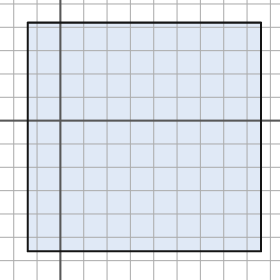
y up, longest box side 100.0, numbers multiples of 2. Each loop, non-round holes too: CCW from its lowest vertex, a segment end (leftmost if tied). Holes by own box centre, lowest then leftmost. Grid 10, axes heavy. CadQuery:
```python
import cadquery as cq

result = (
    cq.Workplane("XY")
    .moveTo(-14.0, -56.0)
    .lineTo(86.0, -56.0)
    .lineTo(86.0, 42.0)
    .lineTo(-14.0, 42.0)
    .close()
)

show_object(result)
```